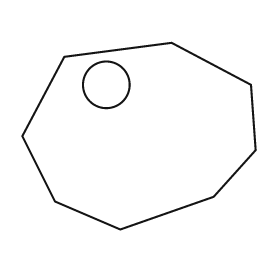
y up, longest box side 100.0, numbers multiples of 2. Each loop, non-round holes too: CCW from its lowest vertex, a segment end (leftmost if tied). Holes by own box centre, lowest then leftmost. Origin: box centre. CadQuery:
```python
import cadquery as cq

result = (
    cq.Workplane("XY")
    .moveTo(-8.0, -40.0)
    .lineTo(32.0, -26.0)
    .lineTo(50.0, -6.0)
    .lineTo(48.0, 22.0)
    .lineTo(14.0, 40.0)
    .lineTo(-32.0, 34.0)
    .lineTo(-50.0, 0.0)
    .lineTo(-36.0, -28.0)
    .close()
    .moveTo(-14.0, 22.0)
    .circle(10.0)
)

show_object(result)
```